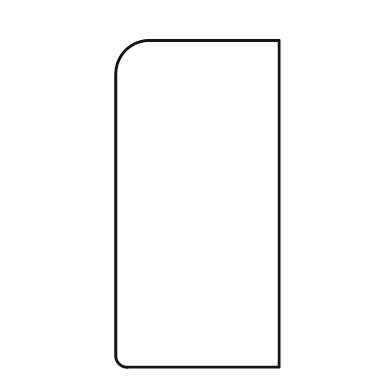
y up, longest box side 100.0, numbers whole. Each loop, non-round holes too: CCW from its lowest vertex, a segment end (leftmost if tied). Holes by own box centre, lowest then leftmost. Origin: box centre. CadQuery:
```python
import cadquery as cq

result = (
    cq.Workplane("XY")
    .moveTo(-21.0, -50.0)
    .lineTo(25.0, -50.0)
    .lineTo(25.0, 50.0)
    .lineTo(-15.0, 50.0)
    .threePointArc((-22.0, 47.0), (-25.0, 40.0))
    .lineTo(-25.0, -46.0)
    .threePointArc((-24.0, -49.0), (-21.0, -50.0))
    .close()
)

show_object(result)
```